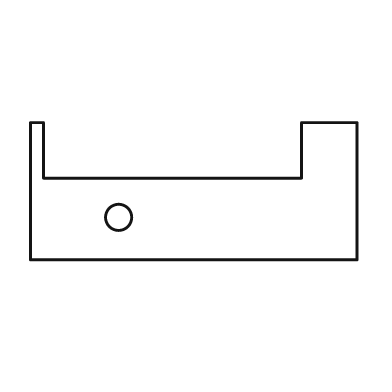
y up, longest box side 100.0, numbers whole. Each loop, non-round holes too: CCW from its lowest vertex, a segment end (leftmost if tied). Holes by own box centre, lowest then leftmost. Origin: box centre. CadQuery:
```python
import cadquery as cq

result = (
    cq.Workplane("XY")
    .moveTo(-50.0, -21.0)
    .lineTo(50.0, -21.0)
    .lineTo(50.0, 21.0)
    .lineTo(33.0, 21.0)
    .lineTo(33.0, 4.0)
    .lineTo(-46.0, 4.0)
    .lineTo(-46.0, 21.0)
    .lineTo(-50.0, 21.0)
    .close()
    .moveTo(-23.0, -8.0)
    .circle(4.0)
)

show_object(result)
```